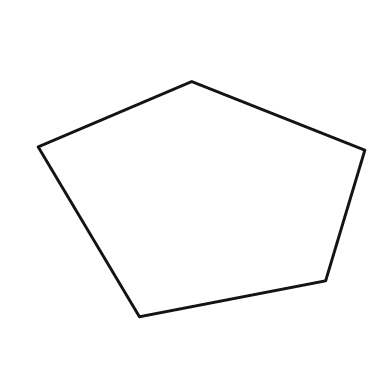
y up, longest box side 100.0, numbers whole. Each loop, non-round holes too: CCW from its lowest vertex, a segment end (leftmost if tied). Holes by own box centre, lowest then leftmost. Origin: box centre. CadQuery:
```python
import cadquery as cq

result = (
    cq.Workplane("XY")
    .moveTo(-19.0, -36.0)
    .lineTo(38.0, -25.0)
    .lineTo(50.0, 15.0)
    .lineTo(-3.0, 36.0)
    .lineTo(-50.0, 16.0)
    .close()
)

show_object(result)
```